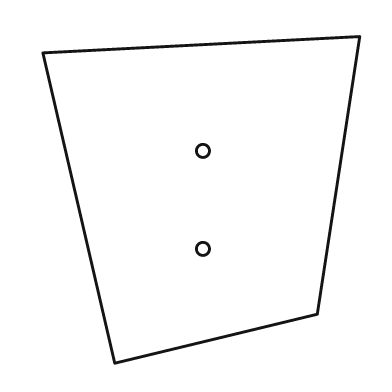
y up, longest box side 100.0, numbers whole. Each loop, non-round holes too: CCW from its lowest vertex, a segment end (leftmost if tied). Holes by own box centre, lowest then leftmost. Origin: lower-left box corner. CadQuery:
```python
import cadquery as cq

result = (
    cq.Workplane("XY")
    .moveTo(22.0, 0.0)
    .lineTo(84.0, 15.0)
    .lineTo(97.0, 100.0)
    .lineTo(0.0, 95.0)
    .close()
    .moveTo(49.0, 35.0)
    .circle(2.0)
    .moveTo(49.0, 65.0)
    .circle(2.0)
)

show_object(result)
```